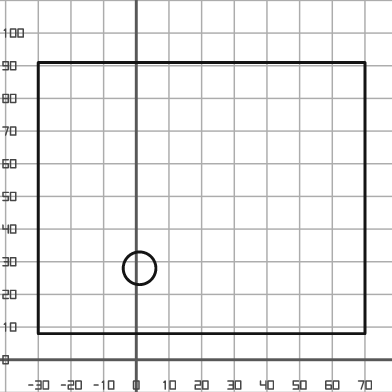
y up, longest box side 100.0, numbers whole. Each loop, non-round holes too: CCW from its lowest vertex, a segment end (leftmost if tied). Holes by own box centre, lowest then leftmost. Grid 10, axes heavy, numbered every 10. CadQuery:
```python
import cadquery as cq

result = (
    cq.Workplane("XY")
    .moveTo(-30.0, 8.0)
    .lineTo(70.0, 8.0)
    .lineTo(70.0, 91.0)
    .lineTo(-30.0, 91.0)
    .close()
    .moveTo(1.0, 28.0)
    .circle(5.0)
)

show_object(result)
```